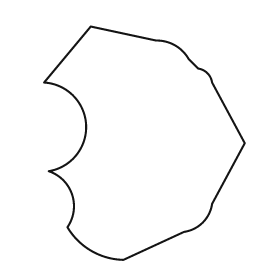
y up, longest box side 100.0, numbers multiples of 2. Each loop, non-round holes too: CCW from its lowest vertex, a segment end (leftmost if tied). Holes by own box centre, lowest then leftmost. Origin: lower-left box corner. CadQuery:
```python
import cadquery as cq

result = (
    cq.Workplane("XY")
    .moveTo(34.0, 0.0)
    .lineTo(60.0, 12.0)
    .threePointArc((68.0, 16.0), (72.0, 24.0))
    .lineTo(86.0, 50.0)
    .lineTo(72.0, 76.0)
    .threePointArc((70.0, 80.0), (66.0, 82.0))
    .lineTo(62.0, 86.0)
    .threePointArc((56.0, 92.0), (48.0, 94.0))
    .lineTo(20.0, 100.0)
    .lineTo(0.0, 76.0)
    .threePointArc((18.0, 58.0), (2.0, 38.0))
    .threePointArc((12.0, 28.0), (10.0, 14.0))
    .threePointArc((20.0, 4.0), (34.0, 0.0))
    .close()
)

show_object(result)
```